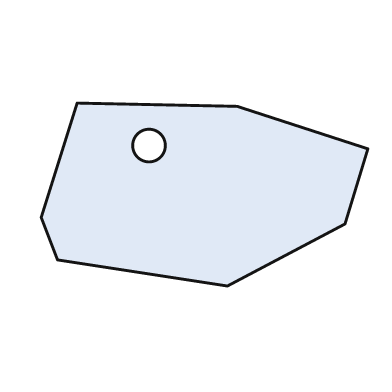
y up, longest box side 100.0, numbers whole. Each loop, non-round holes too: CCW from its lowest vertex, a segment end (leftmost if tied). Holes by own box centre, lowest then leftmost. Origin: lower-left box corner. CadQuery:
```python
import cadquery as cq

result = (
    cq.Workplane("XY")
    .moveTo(57.0, 0.0)
    .lineTo(93.0, 19.0)
    .lineTo(100.0, 42.0)
    .lineTo(60.0, 55.0)
    .lineTo(11.0, 56.0)
    .lineTo(0.0, 21.0)
    .lineTo(5.0, 8.0)
    .close()
    .moveTo(33.0, 43.0)
    .circle(5.0)
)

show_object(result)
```